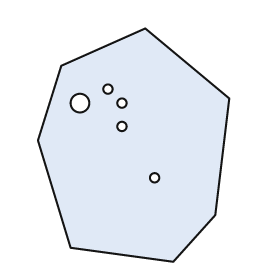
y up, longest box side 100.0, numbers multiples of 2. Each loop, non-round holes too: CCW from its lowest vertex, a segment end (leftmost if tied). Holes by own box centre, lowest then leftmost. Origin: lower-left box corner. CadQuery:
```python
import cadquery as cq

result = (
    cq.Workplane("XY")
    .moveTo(58.0, 0.0)
    .lineTo(76.0, 20.0)
    .lineTo(82.0, 70.0)
    .lineTo(46.0, 100.0)
    .lineTo(10.0, 84.0)
    .lineTo(0.0, 52.0)
    .lineTo(14.0, 6.0)
    .close()
    .moveTo(50.0, 36.0)
    .circle(2.0)
    .moveTo(36.0, 58.0)
    .circle(2.0)
    .moveTo(18.0, 68.0)
    .circle(4.0)
    .moveTo(36.0, 68.0)
    .circle(2.0)
    .moveTo(30.0, 74.0)
    .circle(2.0)
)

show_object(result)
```